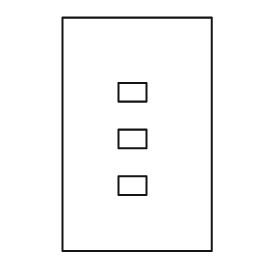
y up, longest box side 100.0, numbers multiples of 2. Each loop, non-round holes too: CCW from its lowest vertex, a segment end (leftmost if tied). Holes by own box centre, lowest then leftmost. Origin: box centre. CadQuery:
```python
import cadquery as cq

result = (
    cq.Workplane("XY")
    .moveTo(-32.0, -50.0)
    .lineTo(32.0, -50.0)
    .lineTo(32.0, 50.0)
    .lineTo(-32.0, 50.0)
    .close()
    .moveTo(-8.0, -26.0)
    .lineTo(4.0, -26.0)
    .lineTo(4.0, -18.0)
    .lineTo(-8.0, -18.0)
    .close()
    .moveTo(-8.0, -6.0)
    .lineTo(4.0, -6.0)
    .lineTo(4.0, 2.0)
    .lineTo(-8.0, 2.0)
    .close()
    .moveTo(-8.0, 14.0)
    .lineTo(4.0, 14.0)
    .lineTo(4.0, 22.0)
    .lineTo(-8.0, 22.0)
    .close()
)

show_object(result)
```